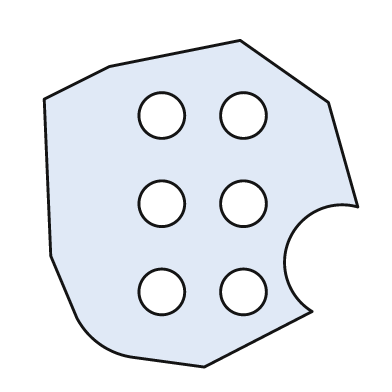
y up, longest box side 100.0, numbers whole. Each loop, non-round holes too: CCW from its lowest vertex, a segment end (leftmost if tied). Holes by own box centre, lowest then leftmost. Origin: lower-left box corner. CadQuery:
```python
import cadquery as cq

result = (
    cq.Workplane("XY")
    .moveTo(49.0, 0.0)
    .lineTo(82.0, 17.0)
    .threePointArc((75.0, 39.0), (96.0, 49.0))
    .lineTo(87.0, 81.0)
    .lineTo(60.0, 100.0)
    .lineTo(20.0, 92.0)
    .lineTo(0.0, 82.0)
    .lineTo(2.0, 34.0)
    .lineTo(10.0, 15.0)
    .threePointArc((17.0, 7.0), (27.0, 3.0))
    .close()
    .moveTo(36.0, 23.0)
    .circle(7.0)
    .moveTo(61.0, 23.0)
    .circle(7.0)
    .moveTo(36.0, 50.0)
    .circle(7.0)
    .moveTo(61.0, 50.0)
    .circle(7.0)
    .moveTo(36.0, 77.0)
    .circle(7.0)
    .moveTo(61.0, 77.0)
    .circle(7.0)
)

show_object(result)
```